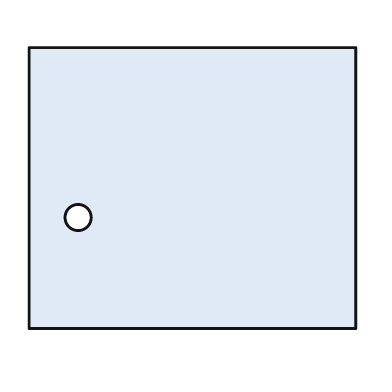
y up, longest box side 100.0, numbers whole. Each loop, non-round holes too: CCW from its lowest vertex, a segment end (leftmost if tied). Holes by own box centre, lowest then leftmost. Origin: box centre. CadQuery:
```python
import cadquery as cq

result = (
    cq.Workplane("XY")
    .moveTo(-50.0, -43.0)
    .lineTo(50.0, -43.0)
    .lineTo(50.0, 43.0)
    .lineTo(-50.0, 43.0)
    .close()
    .moveTo(-35.0, -9.0)
    .circle(4.0)
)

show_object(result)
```